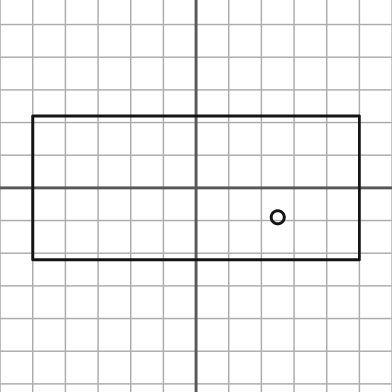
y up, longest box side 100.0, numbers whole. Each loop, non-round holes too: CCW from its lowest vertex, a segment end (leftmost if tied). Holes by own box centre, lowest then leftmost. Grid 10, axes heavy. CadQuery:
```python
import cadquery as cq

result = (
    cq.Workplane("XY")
    .moveTo(-50.0, -22.0)
    .lineTo(50.0, -22.0)
    .lineTo(50.0, 22.0)
    .lineTo(-50.0, 22.0)
    .close()
    .moveTo(25.0, -9.0)
    .circle(2.0)
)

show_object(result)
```